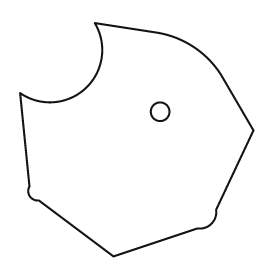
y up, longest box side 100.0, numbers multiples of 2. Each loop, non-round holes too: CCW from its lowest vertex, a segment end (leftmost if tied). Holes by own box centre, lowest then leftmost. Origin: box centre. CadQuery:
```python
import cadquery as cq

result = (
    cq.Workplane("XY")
    .moveTo(-10.0, -50.0)
    .lineTo(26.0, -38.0)
    .threePointArc((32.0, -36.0), (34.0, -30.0))
    .lineTo(50.0, 4.0)
    .lineTo(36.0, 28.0)
    .threePointArc((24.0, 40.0), (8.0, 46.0))
    .lineTo(-18.0, 50.0)
    .threePointArc((-22.0, 22.0), (-50.0, 20.0))
    .lineTo(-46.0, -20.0)
    .threePointArc((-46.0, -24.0), (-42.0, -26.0))
    .close()
    .moveTo(10.0, 12.0)
    .circle(4.0)
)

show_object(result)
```